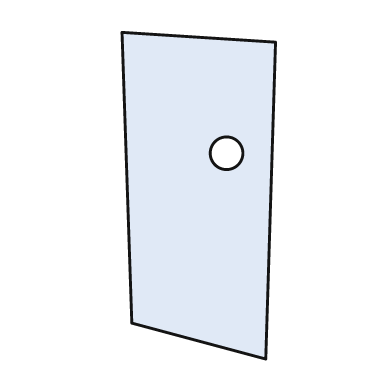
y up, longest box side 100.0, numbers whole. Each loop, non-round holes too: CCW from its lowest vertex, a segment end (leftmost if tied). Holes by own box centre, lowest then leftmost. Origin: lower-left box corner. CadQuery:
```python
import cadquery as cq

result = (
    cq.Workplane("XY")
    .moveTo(44.0, 0.0)
    .lineTo(47.0, 97.0)
    .lineTo(0.0, 100.0)
    .lineTo(3.0, 11.0)
    .close()
    .moveTo(32.0, 63.0)
    .circle(5.0)
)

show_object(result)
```